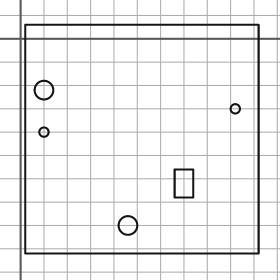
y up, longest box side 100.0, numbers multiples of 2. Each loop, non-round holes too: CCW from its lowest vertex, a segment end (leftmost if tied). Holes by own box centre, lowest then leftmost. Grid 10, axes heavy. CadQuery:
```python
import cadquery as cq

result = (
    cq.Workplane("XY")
    .moveTo(2.0, -92.0)
    .lineTo(102.0, -92.0)
    .lineTo(102.0, 6.0)
    .lineTo(2.0, 6.0)
    .close()
    .moveTo(46.0, -80.0)
    .circle(4.0)
    .moveTo(66.0, -68.0)
    .lineTo(74.0, -68.0)
    .lineTo(74.0, -56.0)
    .lineTo(66.0, -56.0)
    .close()
    .moveTo(10.0, -40.0)
    .circle(2.0)
    .moveTo(92.0, -30.0)
    .circle(2.0)
    .moveTo(10.0, -22.0)
    .circle(4.0)
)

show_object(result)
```